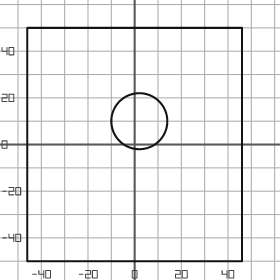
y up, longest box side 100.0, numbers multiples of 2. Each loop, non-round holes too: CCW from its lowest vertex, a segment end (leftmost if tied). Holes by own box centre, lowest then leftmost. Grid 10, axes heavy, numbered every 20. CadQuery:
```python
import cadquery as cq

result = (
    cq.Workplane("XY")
    .moveTo(-46.0, -50.0)
    .lineTo(46.0, -50.0)
    .lineTo(46.0, 50.0)
    .lineTo(-46.0, 50.0)
    .close()
    .moveTo(2.0, 10.0)
    .circle(12.0)
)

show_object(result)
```